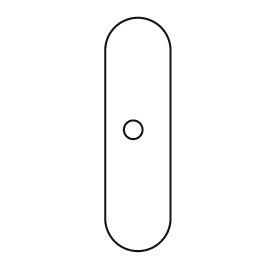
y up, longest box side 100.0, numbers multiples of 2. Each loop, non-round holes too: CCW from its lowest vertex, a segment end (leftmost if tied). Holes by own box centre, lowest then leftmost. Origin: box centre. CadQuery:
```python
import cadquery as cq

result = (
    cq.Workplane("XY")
    .moveTo(-14.0, -36.0)
    .threePointArc((0.0, -50.0), (14.0, -36.0))
    .lineTo(14.0, 36.0)
    .threePointArc((0.0, 50.0), (-14.0, 36.0))
    .close()
    .moveTo(-2.0, 2.0)
    .circle(4.0)
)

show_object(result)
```